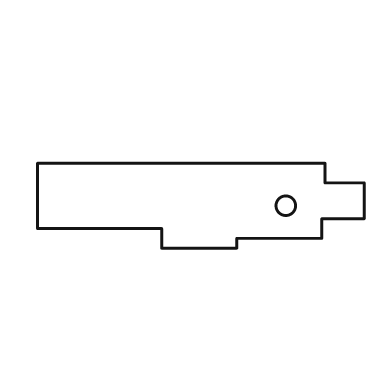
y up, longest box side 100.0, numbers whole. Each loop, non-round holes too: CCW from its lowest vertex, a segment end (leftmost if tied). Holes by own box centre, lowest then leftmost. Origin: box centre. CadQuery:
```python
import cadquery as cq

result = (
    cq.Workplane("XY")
    .moveTo(-12.0, -13.0)
    .lineTo(11.0, -13.0)
    .lineTo(11.0, -10.0)
    .lineTo(37.0, -10.0)
    .lineTo(37.0, -4.0)
    .lineTo(50.0, -4.0)
    .lineTo(50.0, 7.0)
    .lineTo(38.0, 7.0)
    .lineTo(38.0, 13.0)
    .lineTo(-50.0, 13.0)
    .lineTo(-50.0, -7.0)
    .lineTo(-12.0, -7.0)
    .close()
    .moveTo(26.0, 0.0)
    .circle(3.0)
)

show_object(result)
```